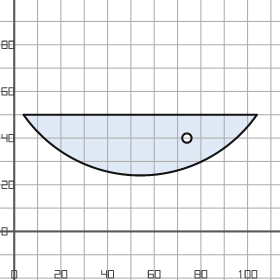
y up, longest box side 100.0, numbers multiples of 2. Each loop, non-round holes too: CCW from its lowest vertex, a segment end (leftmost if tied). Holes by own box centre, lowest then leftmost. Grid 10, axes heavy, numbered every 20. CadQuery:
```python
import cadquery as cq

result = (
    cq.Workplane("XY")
    .moveTo(4.0, 50.0)
    .threePointArc((54.0, 24.0), (104.0, 50.0))
    .close()
    .moveTo(74.0, 40.0)
    .circle(2.0)
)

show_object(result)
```